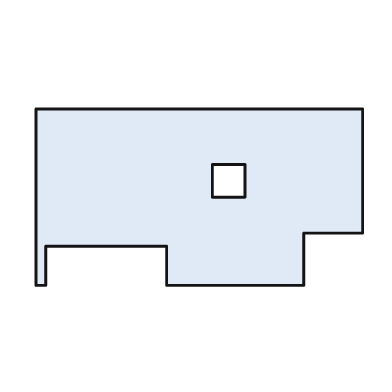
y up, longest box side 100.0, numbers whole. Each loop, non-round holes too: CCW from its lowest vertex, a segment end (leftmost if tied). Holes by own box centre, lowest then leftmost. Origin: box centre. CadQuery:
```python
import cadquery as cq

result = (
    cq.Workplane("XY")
    .moveTo(-50.0, -27.0)
    .lineTo(-47.0, -27.0)
    .lineTo(-47.0, -15.0)
    .lineTo(-10.0, -15.0)
    .lineTo(-10.0, -27.0)
    .lineTo(32.0, -27.0)
    .lineTo(32.0, -11.0)
    .lineTo(50.0, -11.0)
    .lineTo(50.0, 27.0)
    .lineTo(-50.0, 27.0)
    .close()
    .moveTo(4.0, 0.0)
    .lineTo(14.0, 0.0)
    .lineTo(14.0, 10.0)
    .lineTo(4.0, 10.0)
    .close()
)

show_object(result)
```